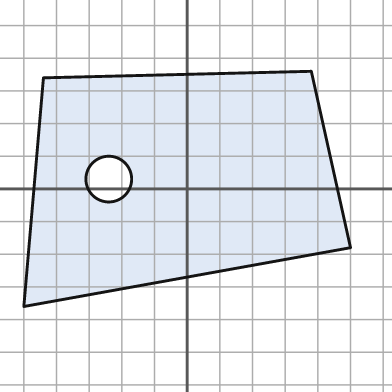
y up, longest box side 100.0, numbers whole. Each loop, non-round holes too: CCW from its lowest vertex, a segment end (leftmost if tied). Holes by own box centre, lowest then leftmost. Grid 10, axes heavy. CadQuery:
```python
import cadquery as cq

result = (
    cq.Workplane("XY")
    .moveTo(-50.0, -36.0)
    .lineTo(50.0, -18.0)
    .lineTo(38.0, 36.0)
    .lineTo(-44.0, 34.0)
    .close()
    .moveTo(-24.0, 3.0)
    .circle(7.0)
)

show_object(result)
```